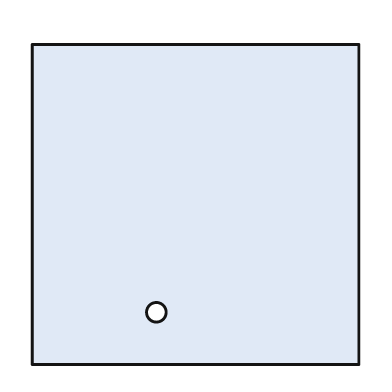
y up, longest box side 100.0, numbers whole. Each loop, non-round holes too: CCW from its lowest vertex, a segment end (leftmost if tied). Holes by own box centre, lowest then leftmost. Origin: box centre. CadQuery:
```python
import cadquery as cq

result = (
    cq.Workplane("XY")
    .moveTo(-50.0, -49.0)
    .lineTo(50.0, -49.0)
    .lineTo(50.0, 49.0)
    .lineTo(-50.0, 49.0)
    .close()
    .moveTo(-12.0, -33.0)
    .circle(3.0)
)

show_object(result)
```